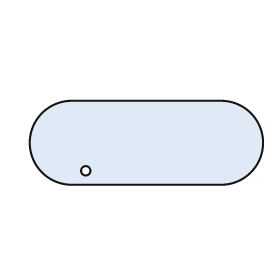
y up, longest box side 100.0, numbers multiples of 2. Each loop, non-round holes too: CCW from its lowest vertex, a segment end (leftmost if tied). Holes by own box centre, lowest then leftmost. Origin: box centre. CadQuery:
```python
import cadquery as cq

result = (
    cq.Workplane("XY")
    .moveTo(-32.0, -18.0)
    .lineTo(32.0, -18.0)
    .threePointArc((50.0, 0.0), (32.0, 18.0))
    .lineTo(-32.0, 18.0)
    .threePointArc((-50.0, 0.0), (-32.0, -18.0))
    .close()
    .moveTo(-26.0, -12.0)
    .circle(2.0)
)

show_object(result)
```